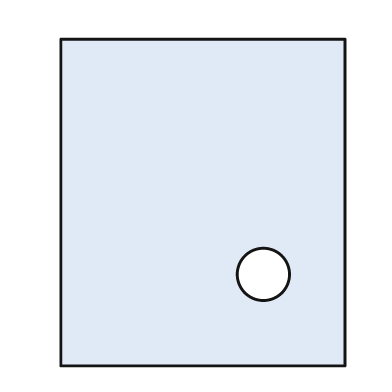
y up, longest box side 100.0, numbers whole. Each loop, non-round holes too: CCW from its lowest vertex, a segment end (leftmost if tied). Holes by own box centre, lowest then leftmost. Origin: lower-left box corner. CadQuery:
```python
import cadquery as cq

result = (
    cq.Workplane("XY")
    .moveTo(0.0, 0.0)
    .lineTo(87.0, 0.0)
    .lineTo(87.0, 100.0)
    .lineTo(0.0, 100.0)
    .close()
    .moveTo(62.0, 28.0)
    .circle(8.0)
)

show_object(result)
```